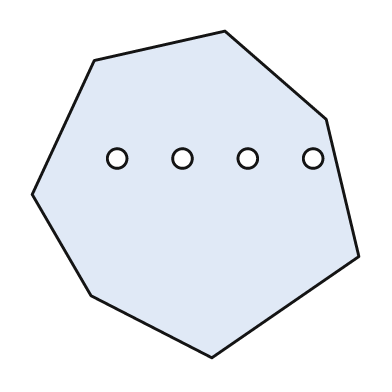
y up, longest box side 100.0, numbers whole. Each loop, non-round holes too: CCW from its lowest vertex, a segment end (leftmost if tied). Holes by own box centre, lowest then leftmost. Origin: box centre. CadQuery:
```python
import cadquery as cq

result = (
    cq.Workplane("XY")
    .moveTo(5.0, -50.0)
    .lineTo(50.0, -19.0)
    .lineTo(40.0, 23.0)
    .lineTo(9.0, 50.0)
    .lineTo(-31.0, 41.0)
    .lineTo(-50.0, 0.0)
    .lineTo(-32.0, -31.0)
    .close()
    .moveTo(-24.0, 11.0)
    .circle(3.0)
    .moveTo(-4.0, 11.0)
    .circle(3.0)
    .moveTo(16.0, 11.0)
    .circle(3.0)
    .moveTo(36.0, 11.0)
    .circle(3.0)
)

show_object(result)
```